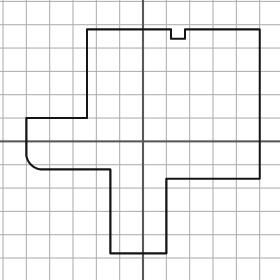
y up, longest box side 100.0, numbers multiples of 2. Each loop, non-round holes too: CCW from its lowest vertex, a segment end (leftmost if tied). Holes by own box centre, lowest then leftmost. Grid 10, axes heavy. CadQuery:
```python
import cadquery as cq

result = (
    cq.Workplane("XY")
    .moveTo(-14.0, -48.0)
    .lineTo(10.0, -48.0)
    .lineTo(10.0, -16.0)
    .lineTo(50.0, -16.0)
    .lineTo(50.0, 48.0)
    .lineTo(18.0, 48.0)
    .lineTo(18.0, 44.0)
    .lineTo(12.0, 44.0)
    .lineTo(12.0, 48.0)
    .lineTo(-24.0, 48.0)
    .lineTo(-24.0, 10.0)
    .lineTo(-50.0, 10.0)
    .lineTo(-50.0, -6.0)
    .threePointArc((-48.0, -10.0), (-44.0, -12.0))
    .lineTo(-14.0, -12.0)
    .close()
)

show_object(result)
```